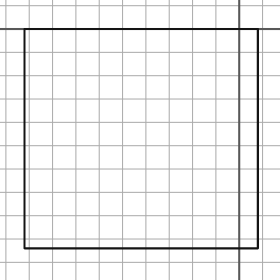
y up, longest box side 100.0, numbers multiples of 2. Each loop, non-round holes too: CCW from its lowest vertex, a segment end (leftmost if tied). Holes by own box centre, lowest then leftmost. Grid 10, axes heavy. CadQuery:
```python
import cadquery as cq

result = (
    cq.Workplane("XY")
    .moveTo(-92.0, -94.0)
    .lineTo(8.0, -94.0)
    .lineTo(8.0, 0.0)
    .lineTo(-92.0, 0.0)
    .close()
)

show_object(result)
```